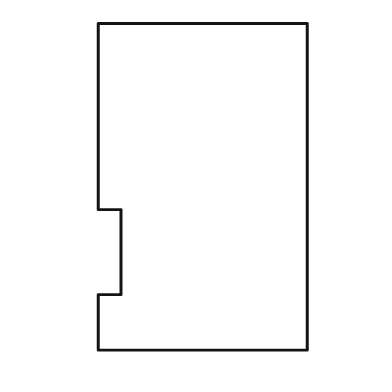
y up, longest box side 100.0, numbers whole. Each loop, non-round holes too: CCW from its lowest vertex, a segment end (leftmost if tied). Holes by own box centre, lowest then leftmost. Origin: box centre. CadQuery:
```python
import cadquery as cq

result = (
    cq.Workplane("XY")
    .moveTo(-32.0, -50.0)
    .lineTo(32.0, -50.0)
    .lineTo(32.0, 50.0)
    .lineTo(-32.0, 50.0)
    .lineTo(-32.0, -7.0)
    .lineTo(-25.0, -7.0)
    .lineTo(-25.0, -33.0)
    .lineTo(-32.0, -33.0)
    .close()
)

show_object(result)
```